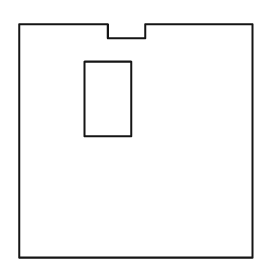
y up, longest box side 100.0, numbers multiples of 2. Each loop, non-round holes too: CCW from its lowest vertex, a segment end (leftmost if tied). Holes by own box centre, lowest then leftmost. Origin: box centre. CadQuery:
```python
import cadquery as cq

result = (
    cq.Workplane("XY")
    .moveTo(-50.0, -50.0)
    .lineTo(50.0, -50.0)
    .lineTo(50.0, 50.0)
    .lineTo(4.0, 50.0)
    .lineTo(4.0, 44.0)
    .lineTo(-12.0, 44.0)
    .lineTo(-12.0, 50.0)
    .lineTo(-50.0, 50.0)
    .close()
    .moveTo(-22.0, 2.0)
    .lineTo(-2.0, 2.0)
    .lineTo(-2.0, 34.0)
    .lineTo(-22.0, 34.0)
    .close()
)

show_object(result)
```